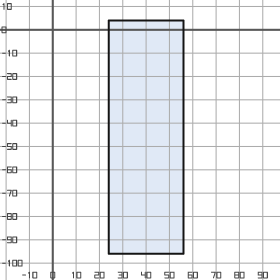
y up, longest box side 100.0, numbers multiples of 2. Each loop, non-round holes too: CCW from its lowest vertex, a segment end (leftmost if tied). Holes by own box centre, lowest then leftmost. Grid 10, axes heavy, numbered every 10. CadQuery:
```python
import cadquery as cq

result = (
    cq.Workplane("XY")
    .moveTo(24.0, -96.0)
    .lineTo(56.0, -96.0)
    .lineTo(56.0, 4.0)
    .lineTo(24.0, 4.0)
    .close()
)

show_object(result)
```